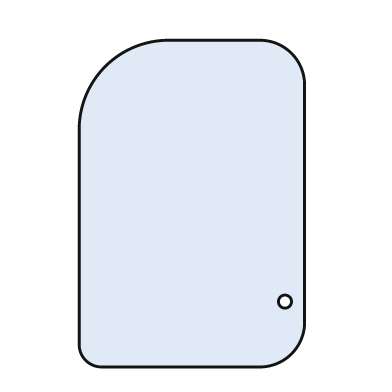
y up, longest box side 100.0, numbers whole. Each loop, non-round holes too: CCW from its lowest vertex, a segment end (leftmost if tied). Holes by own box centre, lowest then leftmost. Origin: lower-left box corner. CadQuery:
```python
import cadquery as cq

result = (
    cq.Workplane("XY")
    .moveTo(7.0, 0.0)
    .lineTo(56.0, 0.0)
    .threePointArc((65.0, 4.0), (69.0, 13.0))
    .lineTo(69.0, 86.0)
    .threePointArc((65.0, 96.0), (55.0, 100.0))
    .lineTo(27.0, 100.0)
    .threePointArc((8.0, 92.0), (0.0, 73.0))
    .lineTo(0.0, 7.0)
    .threePointArc((2.0, 2.0), (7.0, 0.0))
    .close()
    .moveTo(63.0, 20.0)
    .circle(2.0)
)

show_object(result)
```